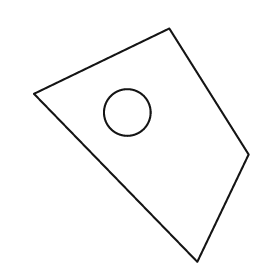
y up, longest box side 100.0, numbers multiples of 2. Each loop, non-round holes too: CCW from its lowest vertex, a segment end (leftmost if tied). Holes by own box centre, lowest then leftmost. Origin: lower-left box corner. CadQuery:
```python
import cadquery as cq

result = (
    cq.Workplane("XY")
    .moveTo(70.0, 0.0)
    .lineTo(92.0, 46.0)
    .lineTo(58.0, 100.0)
    .lineTo(0.0, 72.0)
    .close()
    .moveTo(40.0, 64.0)
    .circle(10.0)
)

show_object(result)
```